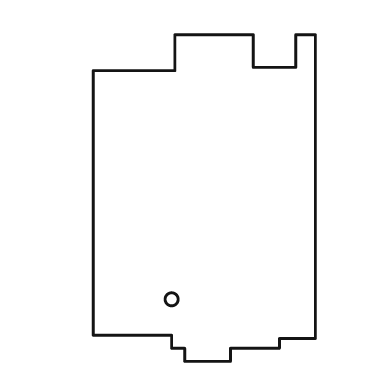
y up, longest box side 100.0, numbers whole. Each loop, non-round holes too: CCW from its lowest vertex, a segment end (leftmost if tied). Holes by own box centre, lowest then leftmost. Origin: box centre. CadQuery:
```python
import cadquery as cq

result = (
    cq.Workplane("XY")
    .moveTo(-6.0, -50.0)
    .lineTo(8.0, -50.0)
    .lineTo(8.0, -46.0)
    .lineTo(23.0, -46.0)
    .lineTo(23.0, -43.0)
    .lineTo(34.0, -43.0)
    .lineTo(34.0, 50.0)
    .lineTo(28.0, 50.0)
    .lineTo(28.0, 40.0)
    .lineTo(15.0, 40.0)
    .lineTo(15.0, 50.0)
    .lineTo(-9.0, 50.0)
    .lineTo(-9.0, 39.0)
    .lineTo(-34.0, 39.0)
    .lineTo(-34.0, -42.0)
    .lineTo(-10.0, -42.0)
    .lineTo(-10.0, -46.0)
    .lineTo(-6.0, -46.0)
    .close()
    .moveTo(-10.0, -31.0)
    .circle(2.0)
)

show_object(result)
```